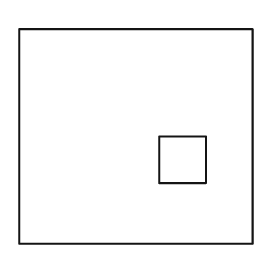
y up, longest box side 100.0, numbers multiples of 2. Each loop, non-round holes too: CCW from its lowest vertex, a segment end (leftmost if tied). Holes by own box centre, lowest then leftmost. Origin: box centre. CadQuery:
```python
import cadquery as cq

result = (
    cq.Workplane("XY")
    .moveTo(-50.0, -46.0)
    .lineTo(50.0, -46.0)
    .lineTo(50.0, 46.0)
    .lineTo(-50.0, 46.0)
    .close()
    .moveTo(10.0, -20.0)
    .lineTo(30.0, -20.0)
    .lineTo(30.0, 0.0)
    .lineTo(10.0, 0.0)
    .close()
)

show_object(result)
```